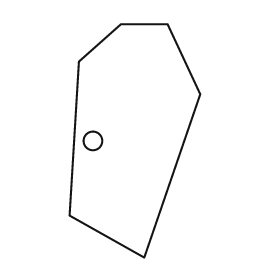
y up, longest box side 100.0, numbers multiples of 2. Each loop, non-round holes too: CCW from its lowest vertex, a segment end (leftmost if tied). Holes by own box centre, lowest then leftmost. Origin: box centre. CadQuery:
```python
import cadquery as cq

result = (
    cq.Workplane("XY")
    .moveTo(4.0, -50.0)
    .lineTo(28.0, 20.0)
    .lineTo(14.0, 50.0)
    .lineTo(-6.0, 50.0)
    .lineTo(-24.0, 34.0)
    .lineTo(-28.0, -32.0)
    .close()
    .moveTo(-18.0, 0.0)
    .circle(4.0)
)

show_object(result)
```